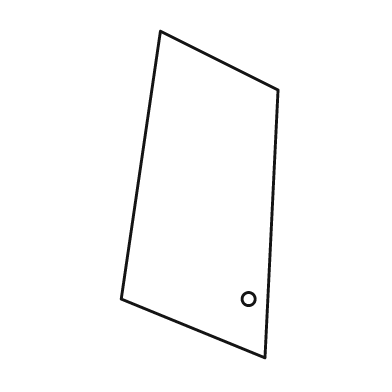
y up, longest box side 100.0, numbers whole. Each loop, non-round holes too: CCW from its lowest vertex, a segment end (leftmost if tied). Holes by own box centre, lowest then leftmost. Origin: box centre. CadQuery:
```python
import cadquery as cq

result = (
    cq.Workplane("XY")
    .moveTo(20.0, -50.0)
    .lineTo(24.0, 32.0)
    .lineTo(-12.0, 50.0)
    .lineTo(-24.0, -32.0)
    .close()
    .moveTo(15.0, -32.0)
    .circle(2.0)
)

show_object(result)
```